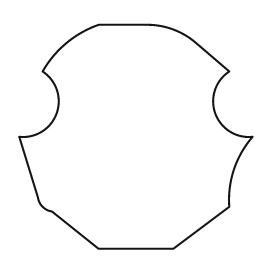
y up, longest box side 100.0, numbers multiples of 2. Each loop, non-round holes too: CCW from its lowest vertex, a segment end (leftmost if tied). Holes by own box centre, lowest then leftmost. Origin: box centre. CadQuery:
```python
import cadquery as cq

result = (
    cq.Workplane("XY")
    .moveTo(-16.0, -48.0)
    .lineTo(16.0, -48.0)
    .lineTo(40.0, -30.0)
    .threePointArc((42.0, -14.0), (50.0, 0.0))
    .threePointArc((34.0, 10.0), (40.0, 28.0))
    .lineTo(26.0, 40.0)
    .threePointArc((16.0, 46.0), (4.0, 48.0))
    .lineTo(-16.0, 48.0)
    .threePointArc((-30.0, 40.0), (-40.0, 28.0))
    .threePointArc((-34.0, 10.0), (-50.0, 0.0))
    .lineTo(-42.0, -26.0)
    .threePointArc((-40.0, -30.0), (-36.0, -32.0))
    .close()
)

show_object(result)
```